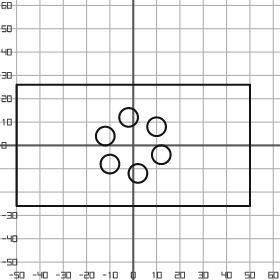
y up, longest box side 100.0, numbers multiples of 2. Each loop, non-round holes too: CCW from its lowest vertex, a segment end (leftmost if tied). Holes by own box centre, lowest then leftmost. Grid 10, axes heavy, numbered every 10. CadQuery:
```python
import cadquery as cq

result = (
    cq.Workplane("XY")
    .moveTo(-50.0, -26.0)
    .lineTo(50.0, -26.0)
    .lineTo(50.0, 26.0)
    .lineTo(-50.0, 26.0)
    .close()
    .moveTo(2.0, -12.0)
    .circle(4.0)
    .moveTo(-10.0, -8.0)
    .circle(4.0)
    .moveTo(12.0, -4.0)
    .circle(4.0)
    .moveTo(-12.0, 4.0)
    .circle(4.0)
    .moveTo(10.0, 8.0)
    .circle(4.0)
    .moveTo(-2.0, 12.0)
    .circle(4.0)
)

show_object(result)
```